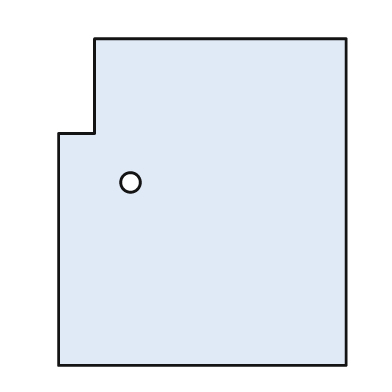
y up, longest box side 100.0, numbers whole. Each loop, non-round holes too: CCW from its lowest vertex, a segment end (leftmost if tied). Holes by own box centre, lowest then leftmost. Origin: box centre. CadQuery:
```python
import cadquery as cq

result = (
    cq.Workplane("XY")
    .moveTo(-44.0, -50.0)
    .lineTo(44.0, -50.0)
    .lineTo(44.0, 50.0)
    .lineTo(-33.0, 50.0)
    .lineTo(-33.0, 21.0)
    .lineTo(-44.0, 21.0)
    .close()
    .moveTo(-22.0, 6.0)
    .circle(3.0)
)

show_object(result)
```